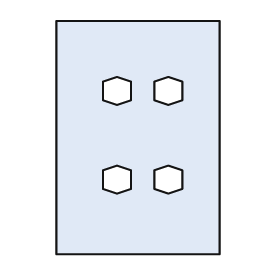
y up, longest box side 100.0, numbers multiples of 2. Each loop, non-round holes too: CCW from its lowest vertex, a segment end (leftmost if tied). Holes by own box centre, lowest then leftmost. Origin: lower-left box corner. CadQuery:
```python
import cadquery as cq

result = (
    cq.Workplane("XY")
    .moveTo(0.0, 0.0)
    .lineTo(70.0, 0.0)
    .lineTo(70.0, 100.0)
    .lineTo(0.0, 100.0)
    .close()
    .moveTo(26.0, 26.0)
    .lineTo(32.0, 28.0)
    .lineTo(32.0, 36.0)
    .lineTo(26.0, 38.0)
    .lineTo(20.0, 36.0)
    .lineTo(20.0, 28.0)
    .close()
    .moveTo(48.0, 26.0)
    .lineTo(54.0, 28.0)
    .lineTo(54.0, 36.0)
    .lineTo(48.0, 38.0)
    .lineTo(42.0, 36.0)
    .lineTo(42.0, 28.0)
    .close()
    .moveTo(26.0, 64.0)
    .lineTo(32.0, 66.0)
    .lineTo(32.0, 74.0)
    .lineTo(26.0, 76.0)
    .lineTo(20.0, 74.0)
    .lineTo(20.0, 66.0)
    .close()
    .moveTo(48.0, 64.0)
    .lineTo(54.0, 66.0)
    .lineTo(54.0, 74.0)
    .lineTo(48.0, 76.0)
    .lineTo(42.0, 74.0)
    .lineTo(42.0, 66.0)
    .close()
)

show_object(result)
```